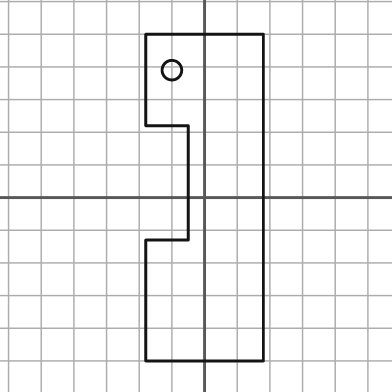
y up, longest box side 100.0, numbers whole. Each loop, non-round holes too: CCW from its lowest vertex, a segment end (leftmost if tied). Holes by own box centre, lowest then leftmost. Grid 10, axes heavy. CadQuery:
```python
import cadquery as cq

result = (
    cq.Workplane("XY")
    .moveTo(-18.0, -50.0)
    .lineTo(18.0, -50.0)
    .lineTo(18.0, 50.0)
    .lineTo(-18.0, 50.0)
    .lineTo(-18.0, 22.0)
    .lineTo(-5.0, 22.0)
    .lineTo(-5.0, -13.0)
    .lineTo(-18.0, -13.0)
    .close()
    .moveTo(-10.0, 39.0)
    .circle(3.0)
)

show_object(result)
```